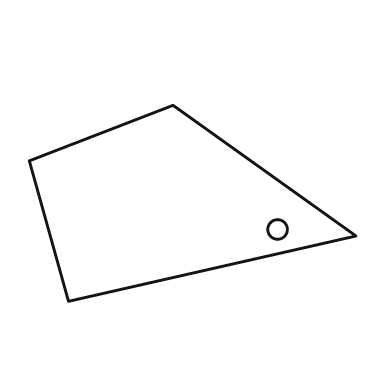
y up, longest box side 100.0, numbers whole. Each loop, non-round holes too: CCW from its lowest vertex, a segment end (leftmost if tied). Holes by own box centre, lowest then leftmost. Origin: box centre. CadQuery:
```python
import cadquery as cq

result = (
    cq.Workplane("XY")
    .moveTo(-38.0, -30.0)
    .lineTo(50.0, -10.0)
    .lineTo(-6.0, 30.0)
    .lineTo(-50.0, 13.0)
    .close()
    .moveTo(26.0, -8.0)
    .circle(3.0)
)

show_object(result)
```